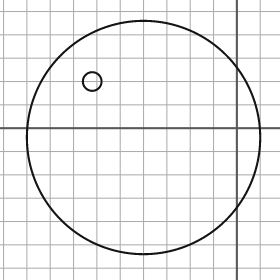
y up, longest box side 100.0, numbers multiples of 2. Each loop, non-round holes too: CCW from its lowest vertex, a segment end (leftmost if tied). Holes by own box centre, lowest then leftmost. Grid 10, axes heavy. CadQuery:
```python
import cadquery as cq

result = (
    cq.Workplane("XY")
    .moveTo(-40.0, -4.0)
    .circle(50.0)
    .moveTo(-62.0, 20.0)
    .circle(4.0)
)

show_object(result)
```